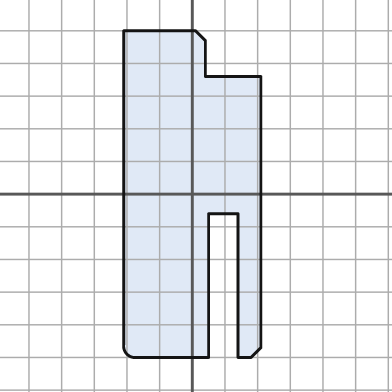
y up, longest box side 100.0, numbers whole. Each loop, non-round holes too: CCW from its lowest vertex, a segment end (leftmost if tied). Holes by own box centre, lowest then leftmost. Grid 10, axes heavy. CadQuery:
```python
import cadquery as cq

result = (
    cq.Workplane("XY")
    .moveTo(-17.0, -50.0)
    .lineTo(5.0, -50.0)
    .lineTo(5.0, -6.0)
    .lineTo(14.0, -6.0)
    .lineTo(14.0, -50.0)
    .lineTo(18.0, -50.0)
    .lineTo(21.0, -47.0)
    .lineTo(21.0, 36.0)
    .lineTo(4.0, 36.0)
    .lineTo(4.0, 47.0)
    .lineTo(1.0, 50.0)
    .lineTo(-21.0, 50.0)
    .lineTo(-21.0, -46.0)
    .threePointArc((-20.0, -49.0), (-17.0, -50.0))
    .close()
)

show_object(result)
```